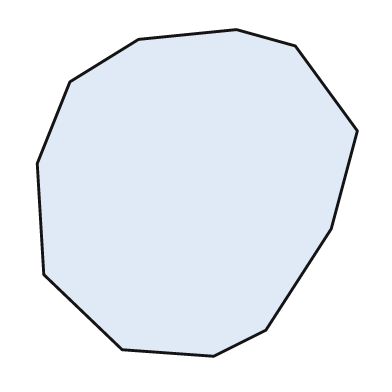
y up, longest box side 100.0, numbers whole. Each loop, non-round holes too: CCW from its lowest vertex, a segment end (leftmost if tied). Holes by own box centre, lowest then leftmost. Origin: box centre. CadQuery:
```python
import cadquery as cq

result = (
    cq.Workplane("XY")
    .moveTo(5.0, -50.0)
    .lineTo(21.0, -42.0)
    .lineTo(41.0, -11.0)
    .lineTo(49.0, 19.0)
    .lineTo(30.0, 45.0)
    .lineTo(12.0, 50.0)
    .lineTo(-18.0, 47.0)
    .lineTo(-39.0, 34.0)
    .lineTo(-49.0, 9.0)
    .lineTo(-47.0, -25.0)
    .lineTo(-23.0, -48.0)
    .close()
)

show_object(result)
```